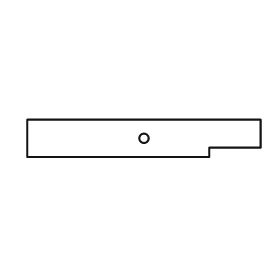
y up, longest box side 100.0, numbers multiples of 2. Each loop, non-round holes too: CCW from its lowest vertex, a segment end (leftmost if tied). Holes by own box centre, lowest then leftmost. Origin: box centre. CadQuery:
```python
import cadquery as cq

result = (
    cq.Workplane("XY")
    .moveTo(-50.0, -8.0)
    .lineTo(28.0, -8.0)
    .lineTo(28.0, -4.0)
    .lineTo(50.0, -4.0)
    .lineTo(50.0, 8.0)
    .lineTo(-50.0, 8.0)
    .close()
    .moveTo(0.0, 0.0)
    .circle(2.0)
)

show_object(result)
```